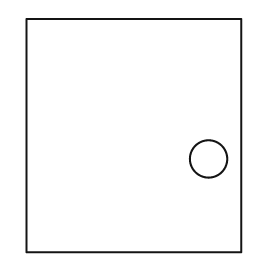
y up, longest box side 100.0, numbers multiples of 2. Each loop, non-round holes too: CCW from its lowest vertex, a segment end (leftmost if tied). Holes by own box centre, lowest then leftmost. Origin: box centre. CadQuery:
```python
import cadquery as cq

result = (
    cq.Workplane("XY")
    .moveTo(-46.0, -50.0)
    .lineTo(46.0, -50.0)
    .lineTo(46.0, 50.0)
    .lineTo(-46.0, 50.0)
    .close()
    .moveTo(32.0, -10.0)
    .circle(8.0)
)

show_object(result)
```